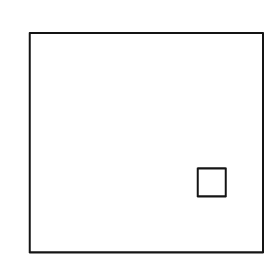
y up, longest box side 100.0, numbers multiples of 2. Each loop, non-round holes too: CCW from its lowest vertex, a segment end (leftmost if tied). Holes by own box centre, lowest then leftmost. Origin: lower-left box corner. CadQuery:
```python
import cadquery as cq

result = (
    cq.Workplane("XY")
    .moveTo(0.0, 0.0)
    .lineTo(100.0, 0.0)
    .lineTo(100.0, 94.0)
    .lineTo(0.0, 94.0)
    .close()
    .moveTo(72.0, 24.0)
    .lineTo(84.0, 24.0)
    .lineTo(84.0, 36.0)
    .lineTo(72.0, 36.0)
    .close()
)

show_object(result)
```